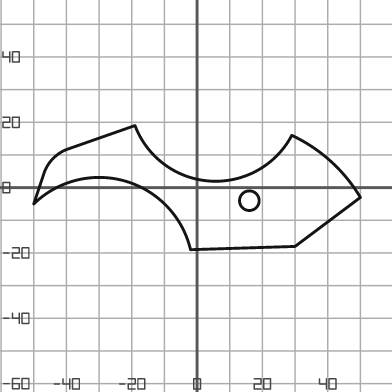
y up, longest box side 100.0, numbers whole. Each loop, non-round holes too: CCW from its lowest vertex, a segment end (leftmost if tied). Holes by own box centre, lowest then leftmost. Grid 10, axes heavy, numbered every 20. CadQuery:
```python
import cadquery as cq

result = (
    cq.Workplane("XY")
    .moveTo(-2.0, -19.0)
    .lineTo(30.0, -18.0)
    .lineTo(50.0, -3.0)
    .threePointArc((41.0, 8.0), (29.0, 16.0))
    .threePointArc((4.0, 2.0), (-19.0, 19.0))
    .lineTo(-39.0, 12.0)
    .threePointArc((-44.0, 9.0), (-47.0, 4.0))
    .lineTo(-50.0, -5.0)
    .threePointArc((-22.0, 2.0), (-2.0, -19.0))
    .close()
    .moveTo(16.0, -4.0)
    .circle(3.0)
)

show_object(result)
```